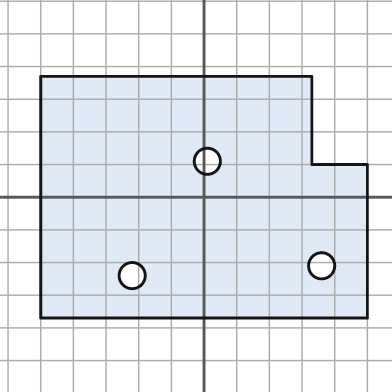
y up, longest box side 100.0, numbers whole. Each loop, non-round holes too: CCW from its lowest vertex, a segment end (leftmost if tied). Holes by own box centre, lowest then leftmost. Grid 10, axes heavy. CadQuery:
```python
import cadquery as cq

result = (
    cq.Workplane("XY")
    .moveTo(-50.0, -37.0)
    .lineTo(50.0, -37.0)
    .lineTo(50.0, 10.0)
    .lineTo(33.0, 10.0)
    .lineTo(33.0, 37.0)
    .lineTo(-50.0, 37.0)
    .close()
    .moveTo(-22.0, -24.0)
    .circle(4.0)
    .moveTo(36.0, -21.0)
    .circle(4.0)
    .moveTo(1.0, 11.0)
    .circle(4.0)
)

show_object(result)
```